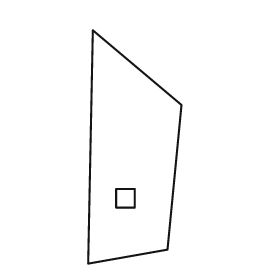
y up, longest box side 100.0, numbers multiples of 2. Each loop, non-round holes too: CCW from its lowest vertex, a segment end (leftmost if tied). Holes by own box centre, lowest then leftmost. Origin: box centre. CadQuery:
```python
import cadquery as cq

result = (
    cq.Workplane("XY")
    .moveTo(-20.0, -50.0)
    .lineTo(14.0, -44.0)
    .lineTo(20.0, 18.0)
    .lineTo(-18.0, 50.0)
    .close()
    .moveTo(-8.0, -26.0)
    .lineTo(0.0, -26.0)
    .lineTo(0.0, -18.0)
    .lineTo(-8.0, -18.0)
    .close()
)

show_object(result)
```